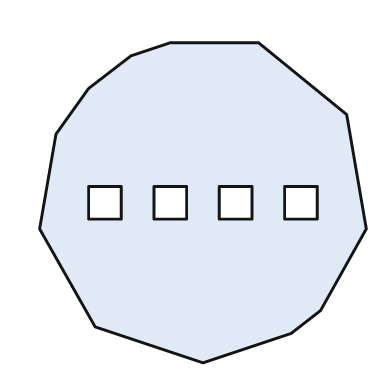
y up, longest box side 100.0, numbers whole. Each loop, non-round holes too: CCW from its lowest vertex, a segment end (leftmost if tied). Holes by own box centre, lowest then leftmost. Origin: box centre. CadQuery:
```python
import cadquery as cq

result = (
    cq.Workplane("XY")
    .moveTo(0.0, -49.0)
    .lineTo(27.0, -40.0)
    .lineTo(36.0, -33.0)
    .lineTo(50.0, -8.0)
    .lineTo(44.0, 27.0)
    .lineTo(17.0, 49.0)
    .lineTo(-10.0, 49.0)
    .lineTo(-22.0, 45.0)
    .lineTo(-35.0, 35.0)
    .lineTo(-45.0, 21.0)
    .lineTo(-50.0, -8.0)
    .lineTo(-33.0, -38.0)
    .close()
    .moveTo(-35.0, -5.0)
    .lineTo(-25.0, -5.0)
    .lineTo(-25.0, 5.0)
    .lineTo(-35.0, 5.0)
    .close()
    .moveTo(-15.0, -5.0)
    .lineTo(-5.0, -5.0)
    .lineTo(-5.0, 5.0)
    .lineTo(-15.0, 5.0)
    .close()
    .moveTo(5.0, -5.0)
    .lineTo(15.0, -5.0)
    .lineTo(15.0, 5.0)
    .lineTo(5.0, 5.0)
    .close()
    .moveTo(25.0, -5.0)
    .lineTo(35.0, -5.0)
    .lineTo(35.0, 5.0)
    .lineTo(25.0, 5.0)
    .close()
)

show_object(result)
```